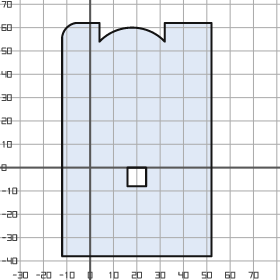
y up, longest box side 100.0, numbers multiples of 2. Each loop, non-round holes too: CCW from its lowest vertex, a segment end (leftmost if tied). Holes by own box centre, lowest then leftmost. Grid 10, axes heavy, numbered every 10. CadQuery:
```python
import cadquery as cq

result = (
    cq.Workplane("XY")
    .moveTo(-12.0, -38.0)
    .lineTo(52.0, -38.0)
    .lineTo(52.0, 62.0)
    .lineTo(32.0, 62.0)
    .lineTo(32.0, 54.0)
    .threePointArc((18.0, 60.0), (4.0, 54.0))
    .lineTo(4.0, 62.0)
    .lineTo(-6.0, 62.0)
    .threePointArc((-10.0, 60.0), (-12.0, 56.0))
    .close()
    .moveTo(16.0, -8.0)
    .lineTo(24.0, -8.0)
    .lineTo(24.0, 0.0)
    .lineTo(16.0, 0.0)
    .close()
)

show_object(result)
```